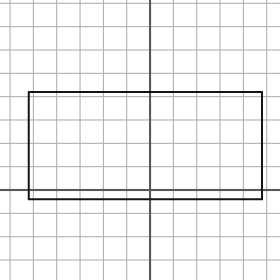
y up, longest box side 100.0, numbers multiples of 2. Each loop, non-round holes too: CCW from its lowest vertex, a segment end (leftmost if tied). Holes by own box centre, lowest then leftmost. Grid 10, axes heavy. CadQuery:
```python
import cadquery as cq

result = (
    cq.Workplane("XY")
    .moveTo(-52.0, -4.0)
    .lineTo(48.0, -4.0)
    .lineTo(48.0, 42.0)
    .lineTo(-52.0, 42.0)
    .close()
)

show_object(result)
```